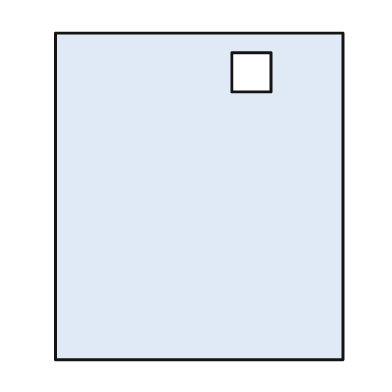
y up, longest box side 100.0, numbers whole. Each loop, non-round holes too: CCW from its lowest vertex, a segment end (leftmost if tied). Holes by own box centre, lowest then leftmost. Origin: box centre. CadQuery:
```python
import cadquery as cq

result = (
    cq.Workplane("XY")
    .moveTo(-44.0, -50.0)
    .lineTo(44.0, -50.0)
    .lineTo(44.0, 50.0)
    .lineTo(-44.0, 50.0)
    .close()
    .moveTo(10.0, 32.0)
    .lineTo(22.0, 32.0)
    .lineTo(22.0, 44.0)
    .lineTo(10.0, 44.0)
    .close()
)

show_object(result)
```